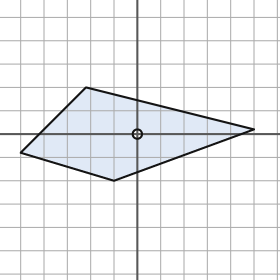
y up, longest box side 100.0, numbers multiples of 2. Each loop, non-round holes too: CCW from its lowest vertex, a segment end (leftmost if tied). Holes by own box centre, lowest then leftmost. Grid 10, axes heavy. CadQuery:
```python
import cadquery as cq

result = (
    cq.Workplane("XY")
    .moveTo(-10.0, -20.0)
    .lineTo(50.0, 2.0)
    .lineTo(-22.0, 20.0)
    .lineTo(-50.0, -8.0)
    .close()
    .moveTo(0.0, 0.0)
    .circle(2.0)
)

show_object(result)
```